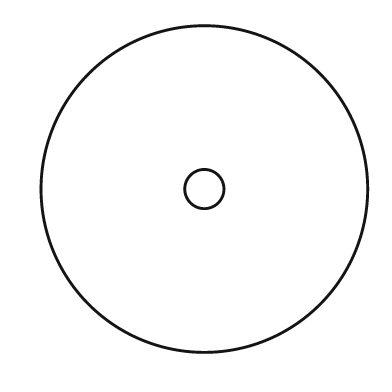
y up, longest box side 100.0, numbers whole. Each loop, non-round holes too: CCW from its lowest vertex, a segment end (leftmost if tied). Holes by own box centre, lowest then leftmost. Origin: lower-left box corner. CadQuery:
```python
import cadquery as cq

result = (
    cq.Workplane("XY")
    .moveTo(50.0, 50.0)
    .circle(50.0)
    .moveTo(50.0, 50.0)
    .circle(6.0)
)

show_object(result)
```